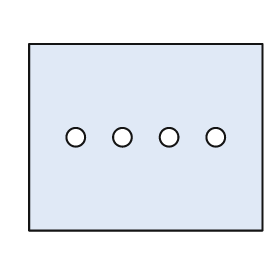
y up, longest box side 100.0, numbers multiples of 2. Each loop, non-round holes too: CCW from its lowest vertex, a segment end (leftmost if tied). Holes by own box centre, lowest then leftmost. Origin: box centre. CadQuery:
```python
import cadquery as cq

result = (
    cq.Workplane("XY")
    .moveTo(-50.0, -40.0)
    .lineTo(50.0, -40.0)
    .lineTo(50.0, 40.0)
    .lineTo(-50.0, 40.0)
    .close()
    .moveTo(-30.0, 0.0)
    .circle(4.0)
    .moveTo(-10.0, 0.0)
    .circle(4.0)
    .moveTo(10.0, 0.0)
    .circle(4.0)
    .moveTo(30.0, 0.0)
    .circle(4.0)
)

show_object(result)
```